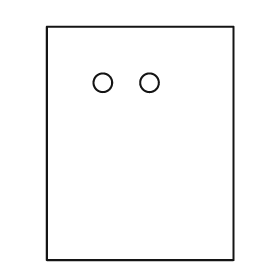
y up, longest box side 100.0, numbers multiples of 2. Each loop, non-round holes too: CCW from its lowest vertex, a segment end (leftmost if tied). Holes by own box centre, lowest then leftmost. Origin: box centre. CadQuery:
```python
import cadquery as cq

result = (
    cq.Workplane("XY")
    .moveTo(-40.0, -50.0)
    .lineTo(40.0, -50.0)
    .lineTo(40.0, 50.0)
    .lineTo(-40.0, 50.0)
    .close()
    .moveTo(-16.0, 26.0)
    .circle(4.0)
    .moveTo(4.0, 26.0)
    .circle(4.0)
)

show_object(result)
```